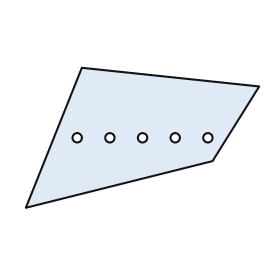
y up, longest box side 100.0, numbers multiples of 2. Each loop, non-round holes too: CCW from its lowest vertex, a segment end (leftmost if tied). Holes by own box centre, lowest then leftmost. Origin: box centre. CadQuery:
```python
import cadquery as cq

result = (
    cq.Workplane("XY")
    .moveTo(-50.0, -30.0)
    .lineTo(30.0, -10.0)
    .lineTo(50.0, 22.0)
    .lineTo(-26.0, 30.0)
    .close()
    .moveTo(-28.0, 0.0)
    .circle(2.0)
    .moveTo(-14.0, 0.0)
    .circle(2.0)
    .moveTo(0.0, 0.0)
    .circle(2.0)
    .moveTo(14.0, 0.0)
    .circle(2.0)
    .moveTo(28.0, 0.0)
    .circle(2.0)
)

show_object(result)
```